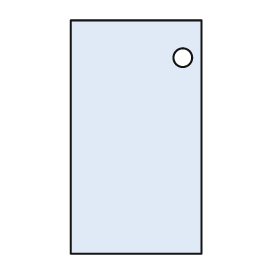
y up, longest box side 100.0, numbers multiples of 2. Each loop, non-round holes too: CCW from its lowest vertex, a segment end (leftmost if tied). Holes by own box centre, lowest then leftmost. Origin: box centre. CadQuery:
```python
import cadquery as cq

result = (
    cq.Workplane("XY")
    .moveTo(-28.0, -50.0)
    .lineTo(28.0, -50.0)
    .lineTo(28.0, 50.0)
    .lineTo(-28.0, 50.0)
    .close()
    .moveTo(20.0, 34.0)
    .circle(4.0)
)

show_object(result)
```